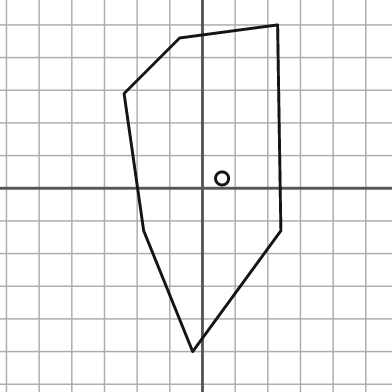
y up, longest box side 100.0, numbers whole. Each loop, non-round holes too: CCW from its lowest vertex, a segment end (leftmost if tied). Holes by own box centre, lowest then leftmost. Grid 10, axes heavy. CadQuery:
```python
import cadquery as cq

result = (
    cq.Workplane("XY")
    .moveTo(-3.0, -50.0)
    .lineTo(24.0, -13.0)
    .lineTo(23.0, 50.0)
    .lineTo(-7.0, 46.0)
    .lineTo(-24.0, 29.0)
    .lineTo(-18.0, -13.0)
    .close()
    .moveTo(6.0, 3.0)
    .circle(2.0)
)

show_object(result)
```